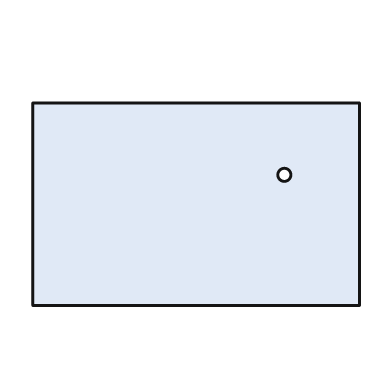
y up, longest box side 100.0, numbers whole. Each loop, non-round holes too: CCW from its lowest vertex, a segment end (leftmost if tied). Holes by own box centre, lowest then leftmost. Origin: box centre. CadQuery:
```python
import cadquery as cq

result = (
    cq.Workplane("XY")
    .moveTo(-50.0, -31.0)
    .lineTo(50.0, -31.0)
    .lineTo(50.0, 31.0)
    .lineTo(-50.0, 31.0)
    .close()
    .moveTo(27.0, 9.0)
    .circle(2.0)
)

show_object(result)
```